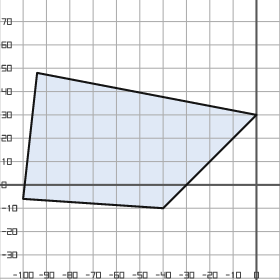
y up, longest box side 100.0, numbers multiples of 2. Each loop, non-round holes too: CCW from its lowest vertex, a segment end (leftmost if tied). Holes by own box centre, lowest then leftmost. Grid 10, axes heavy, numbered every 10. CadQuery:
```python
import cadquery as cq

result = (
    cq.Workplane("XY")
    .moveTo(-40.0, -10.0)
    .lineTo(0.0, 30.0)
    .lineTo(-94.0, 48.0)
    .lineTo(-100.0, -6.0)
    .close()
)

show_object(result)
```